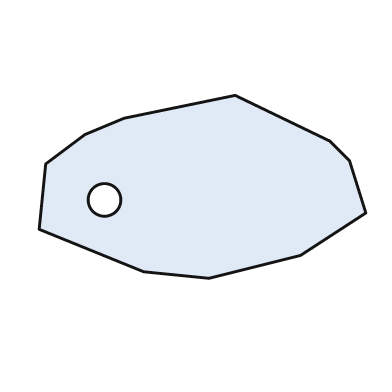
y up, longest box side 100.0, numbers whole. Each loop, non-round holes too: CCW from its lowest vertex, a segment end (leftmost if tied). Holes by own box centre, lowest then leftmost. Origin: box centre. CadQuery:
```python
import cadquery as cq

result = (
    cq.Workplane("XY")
    .moveTo(2.0, -28.0)
    .lineTo(30.0, -21.0)
    .lineTo(50.0, -8.0)
    .lineTo(45.0, 8.0)
    .lineTo(39.0, 14.0)
    .lineTo(10.0, 28.0)
    .lineTo(-24.0, 21.0)
    .lineTo(-36.0, 16.0)
    .lineTo(-48.0, 7.0)
    .lineTo(-50.0, -13.0)
    .lineTo(-18.0, -26.0)
    .close()
    .moveTo(-30.0, -4.0)
    .circle(5.0)
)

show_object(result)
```